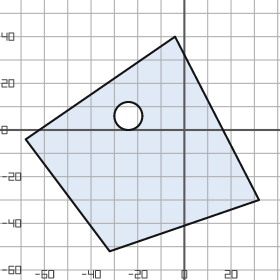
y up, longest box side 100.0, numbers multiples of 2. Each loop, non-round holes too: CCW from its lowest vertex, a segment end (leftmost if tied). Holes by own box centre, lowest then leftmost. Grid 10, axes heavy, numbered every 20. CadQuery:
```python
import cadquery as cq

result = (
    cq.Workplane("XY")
    .moveTo(-32.0, -52.0)
    .lineTo(32.0, -30.0)
    .lineTo(-4.0, 40.0)
    .lineTo(-68.0, -4.0)
    .close()
    .moveTo(-24.0, 6.0)
    .circle(6.0)
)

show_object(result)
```